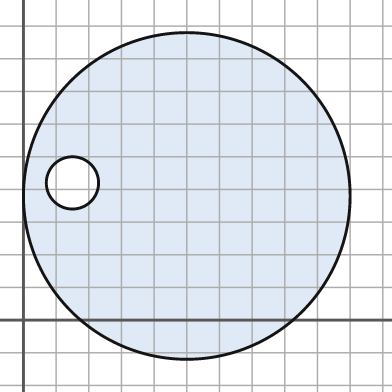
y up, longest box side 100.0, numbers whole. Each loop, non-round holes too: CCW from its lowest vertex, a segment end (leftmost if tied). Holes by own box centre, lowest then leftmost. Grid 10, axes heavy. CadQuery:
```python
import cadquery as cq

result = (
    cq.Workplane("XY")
    .moveTo(50.0, 38.0)
    .circle(50.0)
    .moveTo(15.0, 42.0)
    .circle(8.0)
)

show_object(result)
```